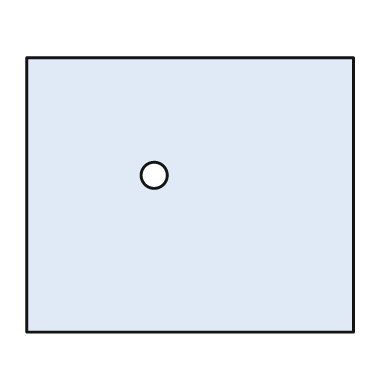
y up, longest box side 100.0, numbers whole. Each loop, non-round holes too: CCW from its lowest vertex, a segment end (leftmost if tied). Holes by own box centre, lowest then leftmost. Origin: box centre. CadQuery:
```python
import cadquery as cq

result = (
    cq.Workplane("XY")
    .moveTo(-50.0, -42.0)
    .lineTo(50.0, -42.0)
    .lineTo(50.0, 42.0)
    .lineTo(-50.0, 42.0)
    .close()
    .moveTo(-11.0, 6.0)
    .circle(4.0)
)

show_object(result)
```